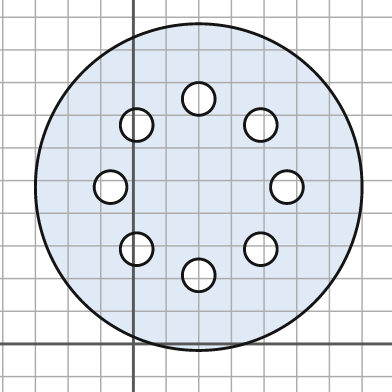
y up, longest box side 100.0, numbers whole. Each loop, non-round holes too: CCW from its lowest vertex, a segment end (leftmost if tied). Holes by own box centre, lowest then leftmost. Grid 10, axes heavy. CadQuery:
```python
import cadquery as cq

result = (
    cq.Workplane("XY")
    .moveTo(20.0, 48.0)
    .circle(50.0)
    .moveTo(20.0, 21.0)
    .circle(5.0)
    .moveTo(1.0, 29.0)
    .circle(5.0)
    .moveTo(39.0, 29.0)
    .circle(5.0)
    .moveTo(-7.0, 48.0)
    .circle(5.0)
    .moveTo(47.0, 48.0)
    .circle(5.0)
    .moveTo(1.0, 67.0)
    .circle(5.0)
    .moveTo(39.0, 67.0)
    .circle(5.0)
    .moveTo(20.0, 75.0)
    .circle(5.0)
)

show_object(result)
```